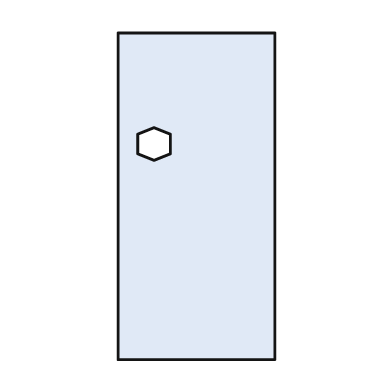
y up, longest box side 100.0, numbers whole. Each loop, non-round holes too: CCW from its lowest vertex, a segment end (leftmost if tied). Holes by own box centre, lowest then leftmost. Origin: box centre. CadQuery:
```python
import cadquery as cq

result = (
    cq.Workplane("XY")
    .moveTo(-24.0, -50.0)
    .lineTo(24.0, -50.0)
    .lineTo(24.0, 50.0)
    .lineTo(-24.0, 50.0)
    .close()
    .moveTo(-13.0, 11.0)
    .lineTo(-8.0, 13.0)
    .lineTo(-8.0, 19.0)
    .lineTo(-13.0, 21.0)
    .lineTo(-18.0, 19.0)
    .lineTo(-18.0, 13.0)
    .close()
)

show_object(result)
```